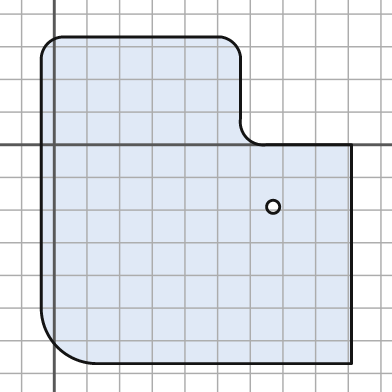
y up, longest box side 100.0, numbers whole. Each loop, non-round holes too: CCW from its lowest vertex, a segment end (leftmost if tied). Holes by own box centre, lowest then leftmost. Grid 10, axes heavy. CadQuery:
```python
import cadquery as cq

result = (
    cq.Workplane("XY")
    .moveTo(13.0, -67.0)
    .lineTo(91.0, -67.0)
    .lineTo(91.0, 0.0)
    .lineTo(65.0, 0.0)
    .threePointArc((59.0, 2.0), (57.0, 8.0))
    .lineTo(57.0, 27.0)
    .threePointArc((55.0, 31.0), (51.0, 33.0))
    .lineTo(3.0, 33.0)
    .threePointArc((-2.0, 31.0), (-4.0, 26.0))
    .lineTo(-4.0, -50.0)
    .threePointArc((1.0, -62.0), (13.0, -67.0))
    .close()
    .moveTo(67.0, -19.0)
    .circle(2.0)
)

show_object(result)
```